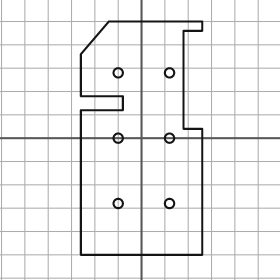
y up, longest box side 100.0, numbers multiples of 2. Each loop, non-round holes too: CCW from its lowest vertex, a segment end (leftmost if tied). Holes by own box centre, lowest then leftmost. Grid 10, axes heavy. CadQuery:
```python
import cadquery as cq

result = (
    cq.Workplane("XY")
    .moveTo(-26.0, -50.0)
    .lineTo(26.0, -50.0)
    .lineTo(26.0, 4.0)
    .lineTo(18.0, 4.0)
    .lineTo(18.0, 46.0)
    .lineTo(26.0, 46.0)
    .lineTo(26.0, 50.0)
    .lineTo(-14.0, 50.0)
    .lineTo(-26.0, 36.0)
    .lineTo(-26.0, 18.0)
    .lineTo(-8.0, 18.0)
    .lineTo(-8.0, 12.0)
    .lineTo(-26.0, 12.0)
    .close()
    .moveTo(-10.0, -28.0)
    .circle(2.0)
    .moveTo(12.0, -28.0)
    .circle(2.0)
    .moveTo(-10.0, 0.0)
    .circle(2.0)
    .moveTo(12.0, 0.0)
    .circle(2.0)
    .moveTo(-10.0, 28.0)
    .circle(2.0)
    .moveTo(12.0, 28.0)
    .circle(2.0)
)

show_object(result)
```